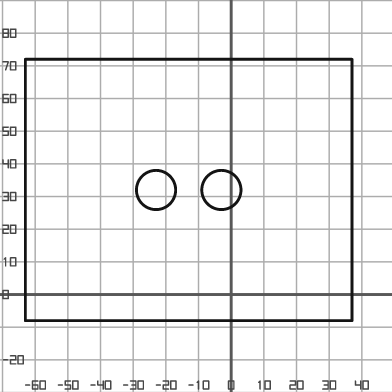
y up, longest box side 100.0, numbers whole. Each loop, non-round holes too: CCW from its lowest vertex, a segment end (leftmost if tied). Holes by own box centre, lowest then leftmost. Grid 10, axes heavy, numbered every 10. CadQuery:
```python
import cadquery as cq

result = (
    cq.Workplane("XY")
    .moveTo(-63.0, -8.0)
    .lineTo(37.0, -8.0)
    .lineTo(37.0, 72.0)
    .lineTo(-63.0, 72.0)
    .close()
    .moveTo(-23.0, 32.0)
    .circle(6.0)
    .moveTo(-3.0, 32.0)
    .circle(6.0)
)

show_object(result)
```